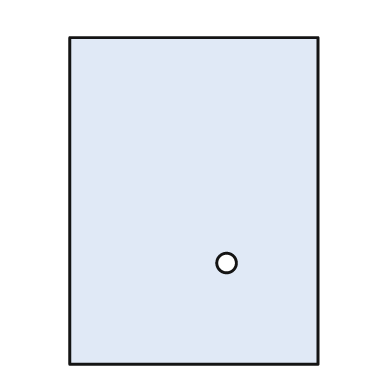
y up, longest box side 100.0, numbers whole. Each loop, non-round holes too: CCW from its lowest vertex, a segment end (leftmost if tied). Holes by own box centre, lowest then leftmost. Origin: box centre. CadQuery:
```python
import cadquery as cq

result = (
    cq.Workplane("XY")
    .moveTo(-38.0, -50.0)
    .lineTo(38.0, -50.0)
    .lineTo(38.0, 50.0)
    .lineTo(-38.0, 50.0)
    .close()
    .moveTo(10.0, -19.0)
    .circle(3.0)
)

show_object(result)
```